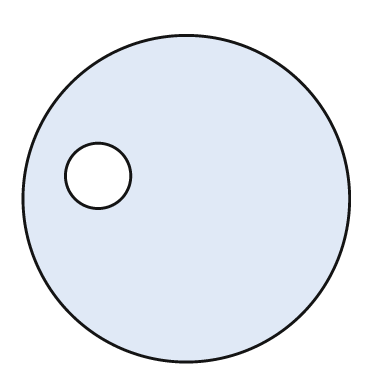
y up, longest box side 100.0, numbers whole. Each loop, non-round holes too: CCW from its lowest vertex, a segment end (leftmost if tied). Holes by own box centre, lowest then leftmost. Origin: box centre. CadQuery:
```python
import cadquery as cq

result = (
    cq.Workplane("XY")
    .moveTo(0.0, 0.0)
    .circle(50.0)
    .moveTo(-27.0, 7.0)
    .circle(10.0)
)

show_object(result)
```